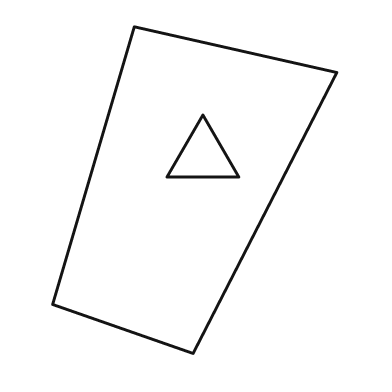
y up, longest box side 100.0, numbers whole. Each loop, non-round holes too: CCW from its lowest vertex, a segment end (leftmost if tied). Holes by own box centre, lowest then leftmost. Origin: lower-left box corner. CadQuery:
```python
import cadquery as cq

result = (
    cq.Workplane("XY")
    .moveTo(43.0, 0.0)
    .lineTo(87.0, 86.0)
    .lineTo(25.0, 100.0)
    .lineTo(0.0, 15.0)
    .close()
    .moveTo(35.0, 54.0)
    .lineTo(57.0, 54.0)
    .lineTo(46.0, 73.0)
    .close()
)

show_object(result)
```